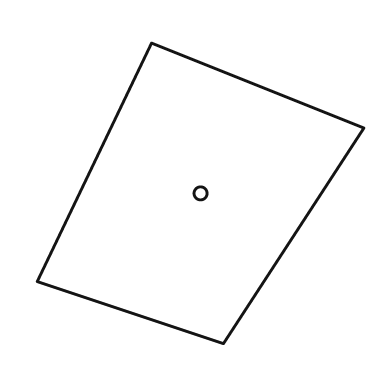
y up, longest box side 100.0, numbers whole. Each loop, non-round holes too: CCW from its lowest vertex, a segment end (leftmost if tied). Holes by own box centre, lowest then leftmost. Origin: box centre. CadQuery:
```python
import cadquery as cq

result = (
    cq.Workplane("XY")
    .moveTo(7.0, -46.0)
    .lineTo(50.0, 20.0)
    .lineTo(-15.0, 46.0)
    .lineTo(-50.0, -27.0)
    .close()
    .moveTo(0.0, 0.0)
    .circle(2.0)
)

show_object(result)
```